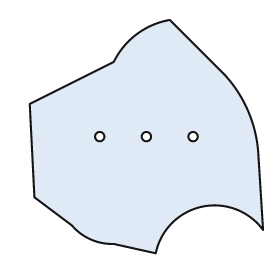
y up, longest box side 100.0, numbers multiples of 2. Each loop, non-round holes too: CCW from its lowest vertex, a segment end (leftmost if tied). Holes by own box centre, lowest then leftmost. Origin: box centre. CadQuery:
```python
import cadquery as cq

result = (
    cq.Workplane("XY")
    .moveTo(4.0, -50.0)
    .threePointArc((24.0, -30.0), (50.0, -40.0))
    .lineTo(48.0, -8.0)
    .threePointArc((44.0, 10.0), (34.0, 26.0))
    .lineTo(10.0, 50.0)
    .threePointArc((-4.0, 44.0), (-14.0, 32.0))
    .lineTo(-50.0, 14.0)
    .lineTo(-48.0, -26.0)
    .lineTo(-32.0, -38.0)
    .threePointArc((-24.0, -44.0), (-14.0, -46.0))
    .close()
    .moveTo(-20.0, 0.0)
    .circle(2.0)
    .moveTo(0.0, 0.0)
    .circle(2.0)
    .moveTo(20.0, 0.0)
    .circle(2.0)
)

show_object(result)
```